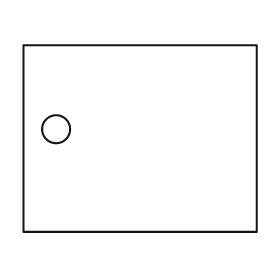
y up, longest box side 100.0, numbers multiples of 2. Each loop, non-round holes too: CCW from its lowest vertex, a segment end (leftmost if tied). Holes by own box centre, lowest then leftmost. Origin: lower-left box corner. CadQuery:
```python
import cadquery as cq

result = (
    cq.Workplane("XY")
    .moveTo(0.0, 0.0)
    .lineTo(100.0, 0.0)
    .lineTo(100.0, 80.0)
    .lineTo(0.0, 80.0)
    .close()
    .moveTo(14.0, 44.0)
    .circle(6.0)
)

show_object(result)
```